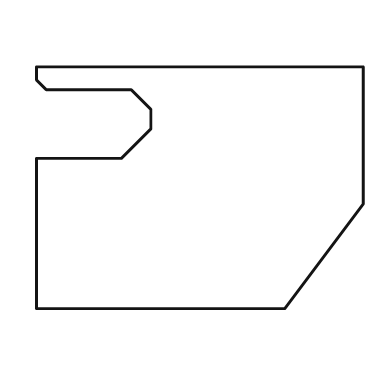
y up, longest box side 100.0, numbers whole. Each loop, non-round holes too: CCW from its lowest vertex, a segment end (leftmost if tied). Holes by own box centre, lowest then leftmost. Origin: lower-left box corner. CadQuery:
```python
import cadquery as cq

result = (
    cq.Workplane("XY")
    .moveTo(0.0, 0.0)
    .lineTo(76.0, 0.0)
    .lineTo(100.0, 32.0)
    .lineTo(100.0, 74.0)
    .lineTo(0.0, 74.0)
    .lineTo(0.0, 70.0)
    .lineTo(3.0, 67.0)
    .lineTo(29.0, 67.0)
    .lineTo(35.0, 61.0)
    .lineTo(35.0, 55.0)
    .lineTo(26.0, 46.0)
    .lineTo(0.0, 46.0)
    .close()
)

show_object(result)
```